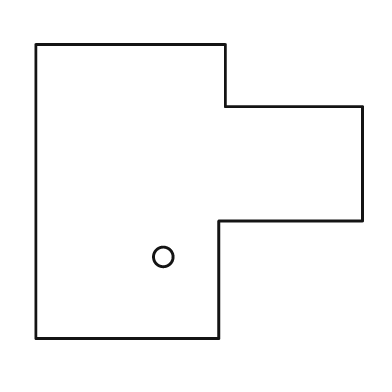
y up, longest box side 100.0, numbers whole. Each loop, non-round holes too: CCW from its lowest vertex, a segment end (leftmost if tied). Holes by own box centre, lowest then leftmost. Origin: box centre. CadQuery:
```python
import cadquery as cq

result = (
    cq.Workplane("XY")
    .moveTo(-50.0, -45.0)
    .lineTo(6.0, -45.0)
    .lineTo(6.0, -9.0)
    .lineTo(50.0, -9.0)
    .lineTo(50.0, 26.0)
    .lineTo(8.0, 26.0)
    .lineTo(8.0, 45.0)
    .lineTo(-50.0, 45.0)
    .close()
    .moveTo(-11.0, -20.0)
    .circle(3.0)
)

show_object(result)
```